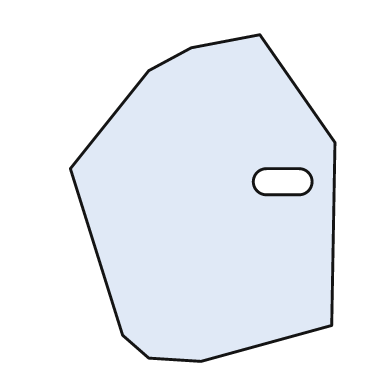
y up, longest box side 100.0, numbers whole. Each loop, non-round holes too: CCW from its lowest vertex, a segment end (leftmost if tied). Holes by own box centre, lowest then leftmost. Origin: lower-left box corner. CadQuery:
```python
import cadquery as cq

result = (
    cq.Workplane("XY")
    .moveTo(40.0, 0.0)
    .lineTo(80.0, 11.0)
    .lineTo(81.0, 67.0)
    .lineTo(58.0, 100.0)
    .lineTo(37.0, 96.0)
    .lineTo(24.0, 89.0)
    .lineTo(0.0, 59.0)
    .lineTo(16.0, 8.0)
    .lineTo(24.0, 1.0)
    .close()
    .moveTo(60.0, 51.0)
    .lineTo(70.0, 51.0)
    .threePointArc((74.0, 55.0), (70.0, 59.0))
    .lineTo(60.0, 59.0)
    .threePointArc((56.0, 55.0), (60.0, 51.0))
    .close()
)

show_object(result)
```